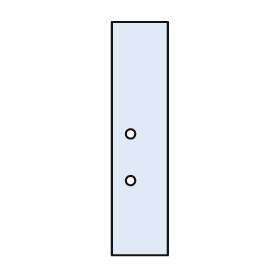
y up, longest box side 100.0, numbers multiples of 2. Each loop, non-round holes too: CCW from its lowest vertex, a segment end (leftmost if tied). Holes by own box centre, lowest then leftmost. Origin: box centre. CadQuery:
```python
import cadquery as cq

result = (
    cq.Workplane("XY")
    .moveTo(-12.0, -50.0)
    .lineTo(12.0, -50.0)
    .lineTo(12.0, 50.0)
    .lineTo(-12.0, 50.0)
    .close()
    .moveTo(-4.0, -18.0)
    .circle(2.0)
    .moveTo(-4.0, 2.0)
    .circle(2.0)
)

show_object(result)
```